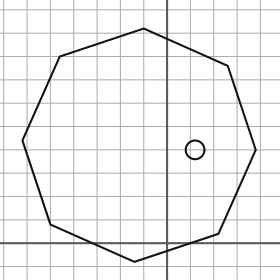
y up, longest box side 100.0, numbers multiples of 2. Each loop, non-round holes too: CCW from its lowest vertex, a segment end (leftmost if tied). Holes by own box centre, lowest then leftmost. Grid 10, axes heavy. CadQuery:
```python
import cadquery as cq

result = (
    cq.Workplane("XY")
    .moveTo(-14.0, -8.0)
    .lineTo(22.0, 4.0)
    .lineTo(38.0, 40.0)
    .lineTo(26.0, 76.0)
    .lineTo(-10.0, 92.0)
    .lineTo(-46.0, 80.0)
    .lineTo(-62.0, 44.0)
    .lineTo(-50.0, 8.0)
    .close()
    .moveTo(12.0, 40.0)
    .circle(4.0)
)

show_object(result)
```